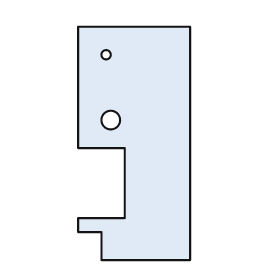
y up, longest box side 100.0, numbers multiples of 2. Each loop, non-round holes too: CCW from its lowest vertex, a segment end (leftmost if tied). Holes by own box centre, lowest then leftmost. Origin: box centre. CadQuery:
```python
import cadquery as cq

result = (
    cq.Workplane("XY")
    .moveTo(-14.0, -50.0)
    .lineTo(24.0, -50.0)
    .lineTo(24.0, 50.0)
    .lineTo(-24.0, 50.0)
    .lineTo(-24.0, -2.0)
    .lineTo(-4.0, -2.0)
    .lineTo(-4.0, -32.0)
    .lineTo(-24.0, -32.0)
    .lineTo(-24.0, -38.0)
    .lineTo(-14.0, -38.0)
    .close()
    .moveTo(-10.0, 10.0)
    .circle(4.0)
    .moveTo(-12.0, 38.0)
    .circle(2.0)
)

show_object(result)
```